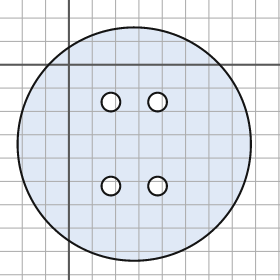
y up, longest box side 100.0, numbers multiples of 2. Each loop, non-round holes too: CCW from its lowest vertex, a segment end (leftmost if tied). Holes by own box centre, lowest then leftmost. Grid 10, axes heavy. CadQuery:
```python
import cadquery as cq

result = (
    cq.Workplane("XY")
    .moveTo(28.0, -34.0)
    .circle(50.0)
    .moveTo(18.0, -52.0)
    .circle(4.0)
    .moveTo(38.0, -52.0)
    .circle(4.0)
    .moveTo(18.0, -16.0)
    .circle(4.0)
    .moveTo(38.0, -16.0)
    .circle(4.0)
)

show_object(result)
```